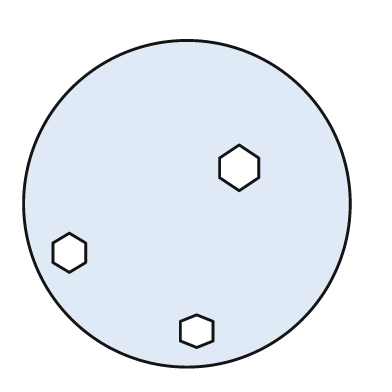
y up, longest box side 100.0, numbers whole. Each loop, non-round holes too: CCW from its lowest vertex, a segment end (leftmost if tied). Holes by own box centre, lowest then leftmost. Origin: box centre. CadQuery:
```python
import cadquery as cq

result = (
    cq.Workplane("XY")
    .moveTo(0.0, 0.0)
    .circle(50.0)
    .moveTo(3.0, -44.0)
    .lineTo(8.0, -42.0)
    .lineTo(8.0, -36.0)
    .lineTo(3.0, -34.0)
    .lineTo(-2.0, -36.0)
    .lineTo(-2.0, -42.0)
    .close()
    .moveTo(-36.0, -21.0)
    .lineTo(-31.0, -18.0)
    .lineTo(-31.0, -12.0)
    .lineTo(-36.0, -9.0)
    .lineTo(-41.0, -12.0)
    .lineTo(-41.0, -18.0)
    .close()
    .moveTo(16.0, 4.0)
    .lineTo(22.0, 8.0)
    .lineTo(22.0, 14.0)
    .lineTo(16.0, 18.0)
    .lineTo(10.0, 14.0)
    .lineTo(10.0, 8.0)
    .close()
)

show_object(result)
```